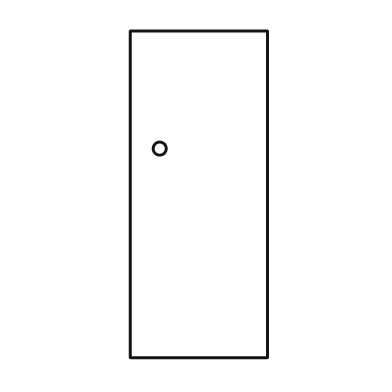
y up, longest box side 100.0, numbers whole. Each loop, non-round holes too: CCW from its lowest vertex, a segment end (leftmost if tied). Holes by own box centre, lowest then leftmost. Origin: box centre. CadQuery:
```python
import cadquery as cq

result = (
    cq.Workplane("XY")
    .moveTo(-21.0, -50.0)
    .lineTo(21.0, -50.0)
    .lineTo(21.0, 50.0)
    .lineTo(-21.0, 50.0)
    .close()
    .moveTo(-12.0, 14.0)
    .circle(2.0)
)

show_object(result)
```